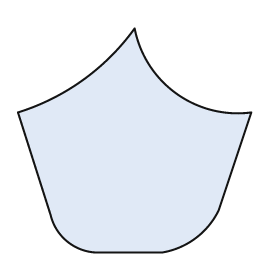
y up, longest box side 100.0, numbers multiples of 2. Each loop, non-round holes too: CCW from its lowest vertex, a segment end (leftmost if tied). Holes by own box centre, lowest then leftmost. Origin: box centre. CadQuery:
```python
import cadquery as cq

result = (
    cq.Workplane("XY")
    .moveTo(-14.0, -48.0)
    .lineTo(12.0, -48.0)
    .threePointArc((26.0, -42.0), (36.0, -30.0))
    .lineTo(50.0, 12.0)
    .threePointArc((18.0, 20.0), (0.0, 48.0))
    .threePointArc((-22.0, 26.0), (-50.0, 12.0))
    .lineTo(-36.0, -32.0)
    .threePointArc((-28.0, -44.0), (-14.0, -48.0))
    .close()
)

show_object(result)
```